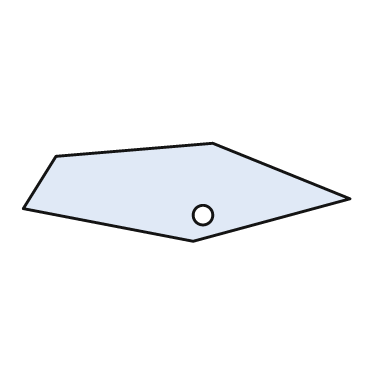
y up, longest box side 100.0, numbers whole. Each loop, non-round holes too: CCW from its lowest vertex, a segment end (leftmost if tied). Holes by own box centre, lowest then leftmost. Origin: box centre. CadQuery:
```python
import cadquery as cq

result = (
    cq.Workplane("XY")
    .moveTo(2.0, -15.0)
    .lineTo(50.0, -2.0)
    .lineTo(8.0, 15.0)
    .lineTo(-40.0, 11.0)
    .lineTo(-50.0, -5.0)
    .close()
    .moveTo(5.0, -7.0)
    .circle(3.0)
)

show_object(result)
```